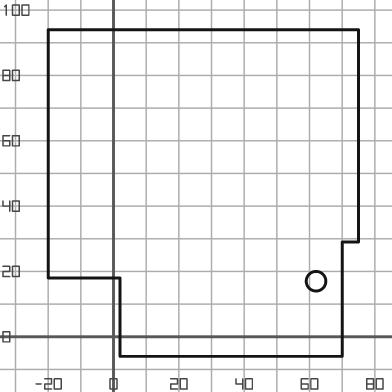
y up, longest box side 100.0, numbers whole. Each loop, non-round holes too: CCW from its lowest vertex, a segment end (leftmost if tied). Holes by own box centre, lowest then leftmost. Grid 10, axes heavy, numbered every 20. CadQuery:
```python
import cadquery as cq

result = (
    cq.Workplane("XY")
    .moveTo(2.0, -6.0)
    .lineTo(70.0, -6.0)
    .lineTo(70.0, 29.0)
    .lineTo(75.0, 29.0)
    .lineTo(75.0, 94.0)
    .lineTo(-20.0, 94.0)
    .lineTo(-20.0, 18.0)
    .lineTo(2.0, 18.0)
    .close()
    .moveTo(62.0, 17.0)
    .circle(3.0)
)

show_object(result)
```